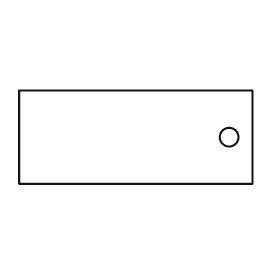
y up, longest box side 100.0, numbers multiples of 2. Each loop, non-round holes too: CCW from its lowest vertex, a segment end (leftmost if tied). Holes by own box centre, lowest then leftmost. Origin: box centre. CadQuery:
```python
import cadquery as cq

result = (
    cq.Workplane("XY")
    .moveTo(-50.0, -20.0)
    .lineTo(50.0, -20.0)
    .lineTo(50.0, 20.0)
    .lineTo(-50.0, 20.0)
    .close()
    .moveTo(40.0, 0.0)
    .circle(4.0)
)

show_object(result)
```